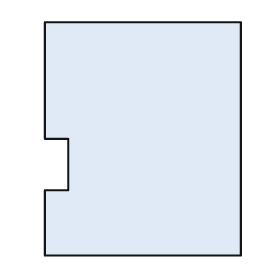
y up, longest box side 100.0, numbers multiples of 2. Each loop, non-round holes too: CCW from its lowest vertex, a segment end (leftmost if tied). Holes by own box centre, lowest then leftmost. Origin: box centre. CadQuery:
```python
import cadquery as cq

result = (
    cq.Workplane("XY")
    .moveTo(-42.0, -50.0)
    .lineTo(42.0, -50.0)
    .lineTo(42.0, 50.0)
    .lineTo(-42.0, 50.0)
    .lineTo(-42.0, 0.0)
    .lineTo(-32.0, 0.0)
    .lineTo(-32.0, -22.0)
    .lineTo(-42.0, -22.0)
    .close()
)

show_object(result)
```